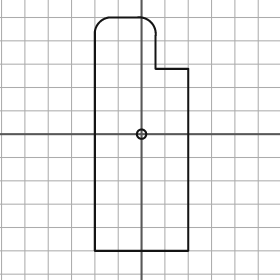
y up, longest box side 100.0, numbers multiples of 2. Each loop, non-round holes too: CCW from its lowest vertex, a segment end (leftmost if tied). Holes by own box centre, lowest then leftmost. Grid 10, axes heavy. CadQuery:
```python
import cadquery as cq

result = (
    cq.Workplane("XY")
    .moveTo(-20.0, -50.0)
    .lineTo(20.0, -50.0)
    .lineTo(20.0, 28.0)
    .lineTo(6.0, 28.0)
    .lineTo(6.0, 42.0)
    .threePointArc((4.0, 48.0), (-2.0, 50.0))
    .lineTo(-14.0, 50.0)
    .threePointArc((-18.0, 48.0), (-20.0, 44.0))
    .close()
    .moveTo(0.0, 0.0)
    .circle(2.0)
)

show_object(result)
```